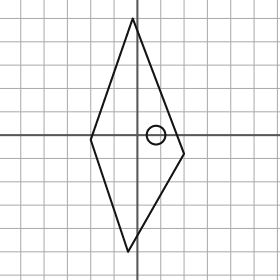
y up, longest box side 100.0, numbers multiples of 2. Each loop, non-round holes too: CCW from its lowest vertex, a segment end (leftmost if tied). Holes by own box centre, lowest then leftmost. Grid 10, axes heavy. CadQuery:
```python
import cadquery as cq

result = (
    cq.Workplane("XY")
    .moveTo(-4.0, -50.0)
    .lineTo(20.0, -8.0)
    .lineTo(-2.0, 50.0)
    .lineTo(-20.0, -2.0)
    .close()
    .moveTo(8.0, 0.0)
    .circle(4.0)
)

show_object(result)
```